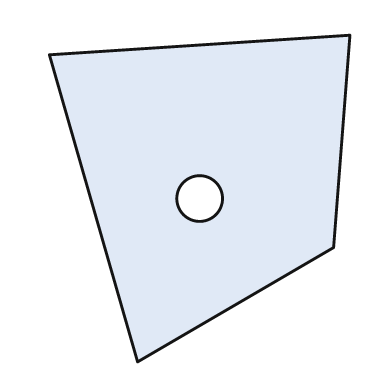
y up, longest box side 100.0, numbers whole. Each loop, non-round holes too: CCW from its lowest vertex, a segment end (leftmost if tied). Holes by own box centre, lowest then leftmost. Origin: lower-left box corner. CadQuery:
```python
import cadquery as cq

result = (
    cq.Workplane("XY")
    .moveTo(27.0, 0.0)
    .lineTo(87.0, 35.0)
    .lineTo(92.0, 100.0)
    .lineTo(0.0, 94.0)
    .close()
    .moveTo(46.0, 50.0)
    .circle(7.0)
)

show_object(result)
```